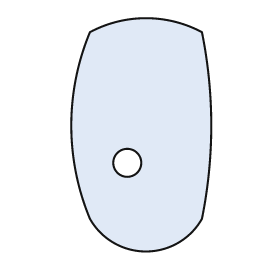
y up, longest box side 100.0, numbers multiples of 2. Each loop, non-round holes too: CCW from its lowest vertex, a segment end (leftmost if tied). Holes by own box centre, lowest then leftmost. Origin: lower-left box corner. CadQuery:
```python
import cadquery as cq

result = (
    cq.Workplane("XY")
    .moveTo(8.0, 14.0)
    .threePointArc((32.0, 0.0), (56.0, 14.0))
    .threePointArc((60.0, 54.0), (56.0, 94.0))
    .threePointArc((32.0, 100.0), (8.0, 94.0))
    .threePointArc((0.0, 54.0), (8.0, 14.0))
    .close()
    .moveTo(24.0, 38.0)
    .circle(6.0)
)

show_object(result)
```